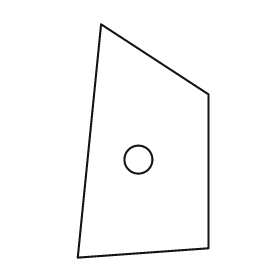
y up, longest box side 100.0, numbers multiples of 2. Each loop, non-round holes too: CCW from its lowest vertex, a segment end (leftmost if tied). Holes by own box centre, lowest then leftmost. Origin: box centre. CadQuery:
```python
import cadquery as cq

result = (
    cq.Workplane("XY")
    .moveTo(-28.0, -50.0)
    .lineTo(28.0, -46.0)
    .lineTo(28.0, 20.0)
    .lineTo(-18.0, 50.0)
    .close()
    .moveTo(-2.0, -8.0)
    .circle(6.0)
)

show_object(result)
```